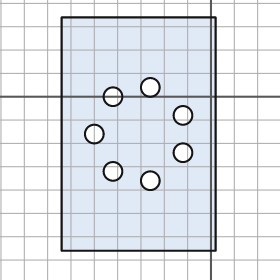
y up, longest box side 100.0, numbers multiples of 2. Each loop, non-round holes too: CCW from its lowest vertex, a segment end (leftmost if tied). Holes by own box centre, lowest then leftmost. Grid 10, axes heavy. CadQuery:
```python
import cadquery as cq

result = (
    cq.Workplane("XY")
    .moveTo(-64.0, -66.0)
    .lineTo(2.0, -66.0)
    .lineTo(2.0, 34.0)
    .lineTo(-64.0, 34.0)
    .close()
    .moveTo(-26.0, -36.0)
    .circle(4.0)
    .moveTo(-42.0, -32.0)
    .circle(4.0)
    .moveTo(-12.0, -24.0)
    .circle(4.0)
    .moveTo(-50.0, -16.0)
    .circle(4.0)
    .moveTo(-12.0, -8.0)
    .circle(4.0)
    .moveTo(-42.0, 0.0)
    .circle(4.0)
    .moveTo(-26.0, 4.0)
    .circle(4.0)
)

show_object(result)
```